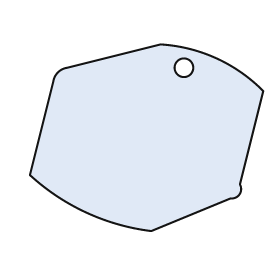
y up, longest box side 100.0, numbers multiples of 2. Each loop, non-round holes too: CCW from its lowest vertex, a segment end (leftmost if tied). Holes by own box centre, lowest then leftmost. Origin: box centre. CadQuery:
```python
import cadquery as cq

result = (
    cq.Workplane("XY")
    .moveTo(2.0, -40.0)
    .lineTo(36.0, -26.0)
    .threePointArc((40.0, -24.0), (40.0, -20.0))
    .lineTo(50.0, 20.0)
    .threePointArc((30.0, 34.0), (6.0, 40.0))
    .lineTo(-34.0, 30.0)
    .threePointArc((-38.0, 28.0), (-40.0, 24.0))
    .lineTo(-50.0, -16.0)
    .threePointArc((-26.0, -32.0), (2.0, -40.0))
    .close()
    .moveTo(16.0, 30.0)
    .circle(4.0)
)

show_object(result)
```